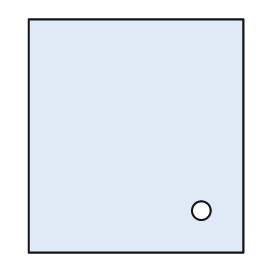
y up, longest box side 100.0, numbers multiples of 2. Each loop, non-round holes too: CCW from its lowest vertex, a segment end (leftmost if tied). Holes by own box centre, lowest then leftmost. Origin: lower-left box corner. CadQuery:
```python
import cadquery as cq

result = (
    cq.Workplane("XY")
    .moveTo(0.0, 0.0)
    .lineTo(92.0, 0.0)
    .lineTo(92.0, 100.0)
    .lineTo(0.0, 100.0)
    .close()
    .moveTo(74.0, 18.0)
    .circle(4.0)
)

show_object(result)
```